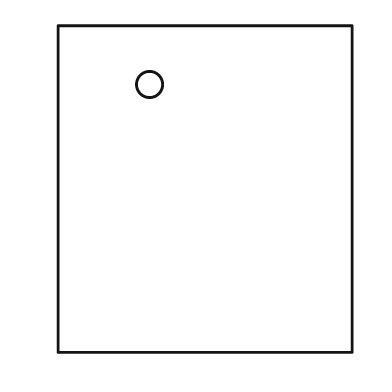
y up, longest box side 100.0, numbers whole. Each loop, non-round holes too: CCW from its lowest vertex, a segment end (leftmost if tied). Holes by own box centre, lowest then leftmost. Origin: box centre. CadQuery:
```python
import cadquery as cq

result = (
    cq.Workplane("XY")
    .moveTo(-45.0, -50.0)
    .lineTo(45.0, -50.0)
    .lineTo(45.0, 50.0)
    .lineTo(-45.0, 50.0)
    .close()
    .moveTo(-17.0, 32.0)
    .circle(4.0)
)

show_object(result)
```